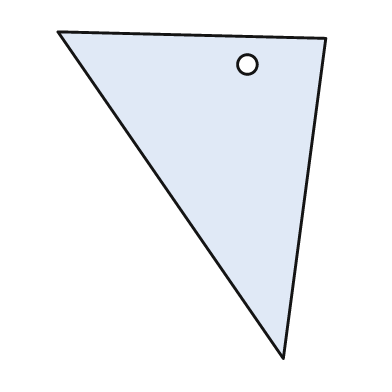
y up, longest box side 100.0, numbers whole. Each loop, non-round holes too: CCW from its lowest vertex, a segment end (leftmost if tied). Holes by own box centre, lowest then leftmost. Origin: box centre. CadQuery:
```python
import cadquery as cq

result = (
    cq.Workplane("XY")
    .moveTo(28.0, -50.0)
    .lineTo(41.0, 48.0)
    .lineTo(-41.0, 50.0)
    .close()
    .moveTo(17.0, 40.0)
    .circle(3.0)
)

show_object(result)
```